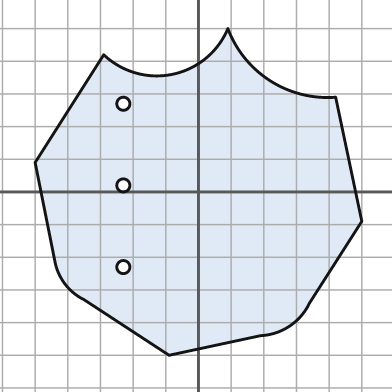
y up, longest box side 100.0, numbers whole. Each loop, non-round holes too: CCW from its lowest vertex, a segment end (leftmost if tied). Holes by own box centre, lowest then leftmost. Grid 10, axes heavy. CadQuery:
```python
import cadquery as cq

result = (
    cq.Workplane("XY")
    .moveTo(-9.0, -50.0)
    .lineTo(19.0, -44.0)
    .threePointArc((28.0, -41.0), (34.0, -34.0))
    .lineTo(50.0, -9.0)
    .lineTo(42.0, 29.0)
    .threePointArc((22.0, 34.0), (9.0, 50.0))
    .threePointArc((-8.0, 36.0), (-29.0, 42.0))
    .lineTo(-50.0, 9.0)
    .lineTo(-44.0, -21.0)
    .threePointArc((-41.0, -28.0), (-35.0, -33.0))
    .close()
    .moveTo(-23.0, -23.0)
    .circle(2.0)
    .moveTo(-23.0, 2.0)
    .circle(2.0)
    .moveTo(-23.0, 27.0)
    .circle(2.0)
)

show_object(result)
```